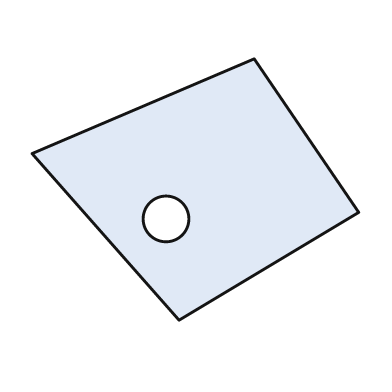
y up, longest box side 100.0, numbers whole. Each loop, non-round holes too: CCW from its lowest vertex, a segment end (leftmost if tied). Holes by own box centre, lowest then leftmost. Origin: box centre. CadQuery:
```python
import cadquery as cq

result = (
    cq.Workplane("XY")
    .moveTo(-5.0, -40.0)
    .lineTo(50.0, -7.0)
    .lineTo(18.0, 40.0)
    .lineTo(-50.0, 11.0)
    .close()
    .moveTo(-9.0, -9.0)
    .circle(7.0)
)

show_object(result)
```